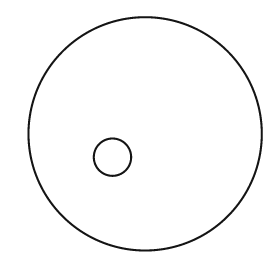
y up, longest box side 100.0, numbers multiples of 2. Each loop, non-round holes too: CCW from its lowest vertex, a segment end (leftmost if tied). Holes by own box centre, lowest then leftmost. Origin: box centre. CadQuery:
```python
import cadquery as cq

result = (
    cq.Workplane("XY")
    .moveTo(0.0, 0.0)
    .circle(50.0)
    .moveTo(-14.0, -10.0)
    .circle(8.0)
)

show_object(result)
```